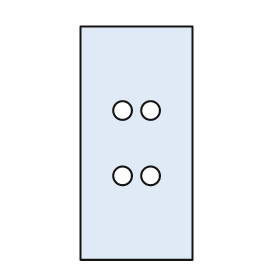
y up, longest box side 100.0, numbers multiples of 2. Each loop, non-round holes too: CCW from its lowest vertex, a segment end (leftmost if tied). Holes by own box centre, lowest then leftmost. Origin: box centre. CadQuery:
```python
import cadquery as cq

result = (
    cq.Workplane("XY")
    .moveTo(-24.0, -50.0)
    .lineTo(24.0, -50.0)
    .lineTo(24.0, 50.0)
    .lineTo(-24.0, 50.0)
    .close()
    .moveTo(-6.0, -14.0)
    .circle(4.0)
    .moveTo(6.0, -14.0)
    .circle(4.0)
    .moveTo(-6.0, 14.0)
    .circle(4.0)
    .moveTo(6.0, 14.0)
    .circle(4.0)
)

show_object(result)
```